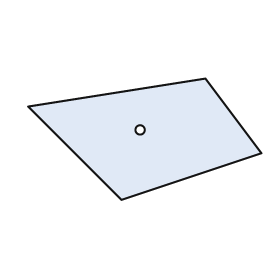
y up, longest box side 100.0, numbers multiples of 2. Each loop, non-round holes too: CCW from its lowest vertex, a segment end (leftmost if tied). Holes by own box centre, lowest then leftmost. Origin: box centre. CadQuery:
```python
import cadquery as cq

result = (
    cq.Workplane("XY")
    .moveTo(-10.0, -26.0)
    .lineTo(50.0, -6.0)
    .lineTo(26.0, 26.0)
    .lineTo(-50.0, 14.0)
    .close()
    .moveTo(-2.0, 4.0)
    .circle(2.0)
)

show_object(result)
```